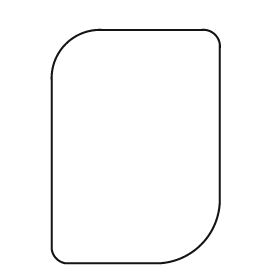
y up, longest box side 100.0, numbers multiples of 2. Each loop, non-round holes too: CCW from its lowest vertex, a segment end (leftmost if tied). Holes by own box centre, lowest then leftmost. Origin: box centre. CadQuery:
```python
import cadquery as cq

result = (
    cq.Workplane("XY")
    .moveTo(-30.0, -50.0)
    .lineTo(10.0, -50.0)
    .threePointArc((28.0, -42.0), (36.0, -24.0))
    .lineTo(36.0, 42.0)
    .threePointArc((34.0, 48.0), (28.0, 50.0))
    .lineTo(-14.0, 50.0)
    .threePointArc((-30.0, 44.0), (-36.0, 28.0))
    .lineTo(-36.0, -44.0)
    .threePointArc((-34.0, -48.0), (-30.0, -50.0))
    .close()
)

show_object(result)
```